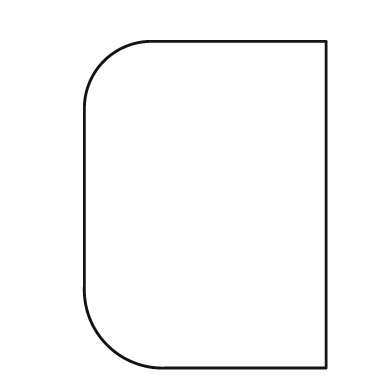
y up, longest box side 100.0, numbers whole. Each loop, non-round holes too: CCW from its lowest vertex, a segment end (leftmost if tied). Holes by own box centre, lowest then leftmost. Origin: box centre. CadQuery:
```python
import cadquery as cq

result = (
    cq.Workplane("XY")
    .moveTo(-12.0, -50.0)
    .lineTo(37.0, -50.0)
    .lineTo(37.0, 50.0)
    .lineTo(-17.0, 50.0)
    .threePointArc((-31.0, 44.0), (-37.0, 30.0))
    .lineTo(-37.0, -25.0)
    .threePointArc((-30.0, -43.0), (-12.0, -50.0))
    .close()
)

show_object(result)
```